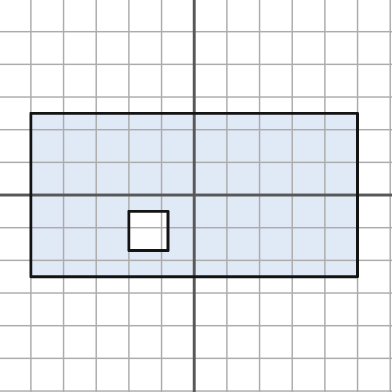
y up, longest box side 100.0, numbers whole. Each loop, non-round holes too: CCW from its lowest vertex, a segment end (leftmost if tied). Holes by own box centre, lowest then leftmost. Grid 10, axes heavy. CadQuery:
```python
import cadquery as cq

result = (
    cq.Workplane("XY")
    .moveTo(-50.0, -25.0)
    .lineTo(50.0, -25.0)
    .lineTo(50.0, 25.0)
    .lineTo(-50.0, 25.0)
    .close()
    .moveTo(-20.0, -17.0)
    .lineTo(-8.0, -17.0)
    .lineTo(-8.0, -5.0)
    .lineTo(-20.0, -5.0)
    .close()
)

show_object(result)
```